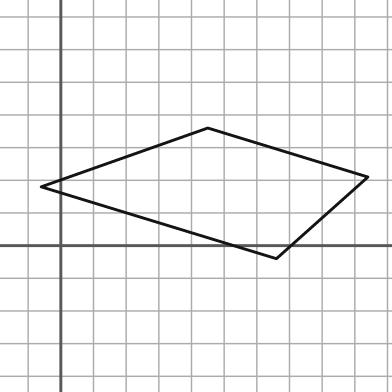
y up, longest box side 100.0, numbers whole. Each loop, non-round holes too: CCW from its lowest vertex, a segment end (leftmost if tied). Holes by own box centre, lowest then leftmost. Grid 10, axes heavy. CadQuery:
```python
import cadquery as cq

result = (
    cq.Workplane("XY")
    .moveTo(66.0, -4.0)
    .lineTo(94.0, 21.0)
    .lineTo(45.0, 36.0)
    .lineTo(-6.0, 18.0)
    .close()
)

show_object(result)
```